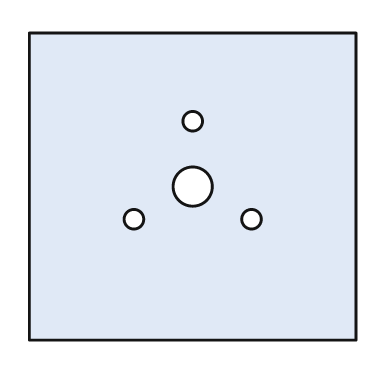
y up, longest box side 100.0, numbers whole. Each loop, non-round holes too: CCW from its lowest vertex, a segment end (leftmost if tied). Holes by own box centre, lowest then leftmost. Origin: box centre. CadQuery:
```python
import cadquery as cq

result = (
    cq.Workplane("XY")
    .moveTo(-50.0, -47.0)
    .lineTo(50.0, -47.0)
    .lineTo(50.0, 47.0)
    .lineTo(-50.0, 47.0)
    .close()
    .moveTo(-18.0, -10.0)
    .circle(3.0)
    .moveTo(18.0, -10.0)
    .circle(3.0)
    .moveTo(0.0, 0.0)
    .circle(6.0)
    .moveTo(0.0, 20.0)
    .circle(3.0)
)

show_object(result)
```